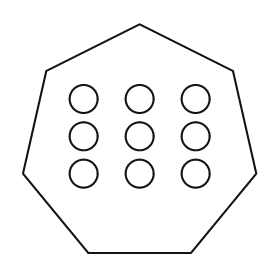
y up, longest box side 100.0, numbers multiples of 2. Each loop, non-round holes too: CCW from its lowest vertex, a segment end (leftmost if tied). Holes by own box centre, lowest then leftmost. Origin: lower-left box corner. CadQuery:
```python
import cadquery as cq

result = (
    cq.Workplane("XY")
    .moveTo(28.0, 0.0)
    .lineTo(72.0, 0.0)
    .lineTo(100.0, 34.0)
    .lineTo(90.0, 78.0)
    .lineTo(50.0, 98.0)
    .lineTo(10.0, 78.0)
    .lineTo(0.0, 34.0)
    .close()
    .moveTo(26.0, 34.0)
    .circle(6.0)
    .moveTo(50.0, 34.0)
    .circle(6.0)
    .moveTo(74.0, 34.0)
    .circle(6.0)
    .moveTo(26.0, 50.0)
    .circle(6.0)
    .moveTo(50.0, 50.0)
    .circle(6.0)
    .moveTo(74.0, 50.0)
    .circle(6.0)
    .moveTo(26.0, 66.0)
    .circle(6.0)
    .moveTo(50.0, 66.0)
    .circle(6.0)
    .moveTo(74.0, 66.0)
    .circle(6.0)
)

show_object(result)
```